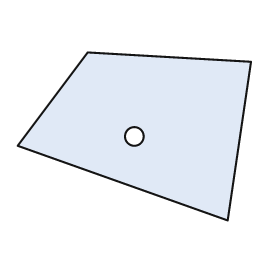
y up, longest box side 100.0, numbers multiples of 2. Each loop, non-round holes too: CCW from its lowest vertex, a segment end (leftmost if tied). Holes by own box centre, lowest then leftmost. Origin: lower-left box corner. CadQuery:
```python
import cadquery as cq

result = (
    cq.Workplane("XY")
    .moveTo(90.0, 0.0)
    .lineTo(100.0, 68.0)
    .lineTo(30.0, 72.0)
    .lineTo(0.0, 32.0)
    .close()
    .moveTo(50.0, 36.0)
    .circle(4.0)
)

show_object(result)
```